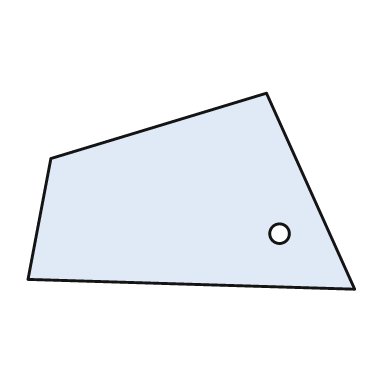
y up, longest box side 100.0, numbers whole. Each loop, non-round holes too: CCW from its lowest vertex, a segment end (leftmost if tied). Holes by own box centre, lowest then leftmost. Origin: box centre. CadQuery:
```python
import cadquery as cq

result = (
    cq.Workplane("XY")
    .moveTo(50.0, -30.0)
    .lineTo(23.0, 30.0)
    .lineTo(-43.0, 10.0)
    .lineTo(-50.0, -27.0)
    .close()
    .moveTo(27.0, -13.0)
    .circle(3.0)
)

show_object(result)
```